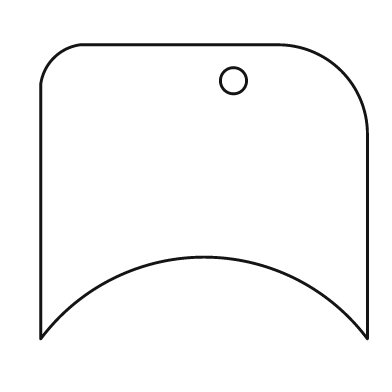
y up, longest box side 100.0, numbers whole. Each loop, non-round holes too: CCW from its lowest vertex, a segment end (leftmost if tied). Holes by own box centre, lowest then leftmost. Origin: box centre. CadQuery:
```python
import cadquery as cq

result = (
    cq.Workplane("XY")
    .moveTo(-50.0, -45.0)
    .threePointArc((0.0, -20.0), (50.0, -45.0))
    .lineTo(50.0, 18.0)
    .threePointArc((42.0, 37.0), (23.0, 45.0))
    .lineTo(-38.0, 45.0)
    .threePointArc((-46.0, 41.0), (-50.0, 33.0))
    .close()
    .moveTo(9.0, 34.0)
    .circle(4.0)
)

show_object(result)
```